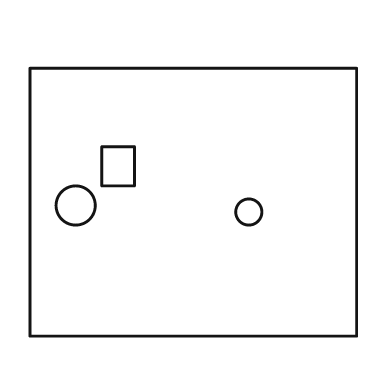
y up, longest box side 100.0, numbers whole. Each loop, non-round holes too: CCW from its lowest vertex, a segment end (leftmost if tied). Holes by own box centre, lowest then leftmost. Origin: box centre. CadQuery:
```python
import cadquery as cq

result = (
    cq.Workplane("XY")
    .moveTo(-50.0, -41.0)
    .lineTo(50.0, -41.0)
    .lineTo(50.0, 41.0)
    .lineTo(-50.0, 41.0)
    .close()
    .moveTo(17.0, -3.0)
    .circle(4.0)
    .moveTo(-36.0, -1.0)
    .circle(6.0)
    .moveTo(-28.0, 5.0)
    .lineTo(-18.0, 5.0)
    .lineTo(-18.0, 17.0)
    .lineTo(-28.0, 17.0)
    .close()
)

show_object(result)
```